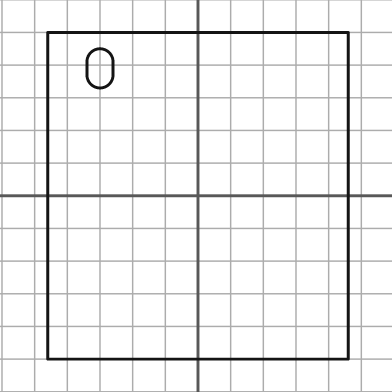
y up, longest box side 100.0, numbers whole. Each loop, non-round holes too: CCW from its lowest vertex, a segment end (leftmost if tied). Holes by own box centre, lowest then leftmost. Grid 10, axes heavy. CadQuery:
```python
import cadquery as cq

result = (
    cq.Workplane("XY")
    .moveTo(-46.0, -50.0)
    .lineTo(46.0, -50.0)
    .lineTo(46.0, 50.0)
    .lineTo(-46.0, 50.0)
    .close()
    .moveTo(-34.0, 37.0)
    .threePointArc((-30.0, 33.0), (-26.0, 37.0))
    .lineTo(-26.0, 41.0)
    .threePointArc((-30.0, 45.0), (-34.0, 41.0))
    .close()
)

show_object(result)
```